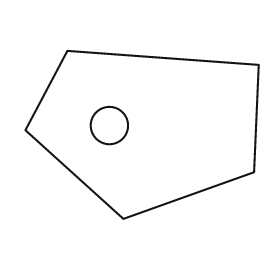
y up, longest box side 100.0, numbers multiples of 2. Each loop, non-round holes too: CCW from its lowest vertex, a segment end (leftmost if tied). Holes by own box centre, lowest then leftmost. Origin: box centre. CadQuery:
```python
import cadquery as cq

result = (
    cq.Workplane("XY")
    .moveTo(-8.0, -36.0)
    .lineTo(48.0, -16.0)
    .lineTo(50.0, 30.0)
    .lineTo(-32.0, 36.0)
    .lineTo(-50.0, 2.0)
    .close()
    .moveTo(-14.0, 4.0)
    .circle(8.0)
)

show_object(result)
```